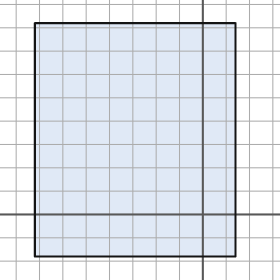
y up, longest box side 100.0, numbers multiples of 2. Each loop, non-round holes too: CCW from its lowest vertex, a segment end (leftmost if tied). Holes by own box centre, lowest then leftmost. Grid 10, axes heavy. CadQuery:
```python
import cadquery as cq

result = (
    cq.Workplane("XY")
    .moveTo(-72.0, -18.0)
    .lineTo(14.0, -18.0)
    .lineTo(14.0, 82.0)
    .lineTo(-72.0, 82.0)
    .close()
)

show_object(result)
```